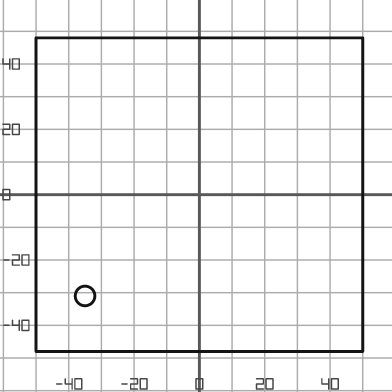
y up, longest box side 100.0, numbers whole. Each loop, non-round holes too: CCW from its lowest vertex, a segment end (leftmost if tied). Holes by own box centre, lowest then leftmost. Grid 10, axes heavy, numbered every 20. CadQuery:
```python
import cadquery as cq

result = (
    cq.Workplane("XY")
    .moveTo(-50.0, -48.0)
    .lineTo(50.0, -48.0)
    .lineTo(50.0, 48.0)
    .lineTo(-50.0, 48.0)
    .close()
    .moveTo(-35.0, -31.0)
    .circle(3.0)
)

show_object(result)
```